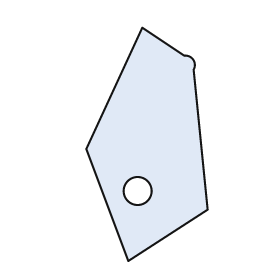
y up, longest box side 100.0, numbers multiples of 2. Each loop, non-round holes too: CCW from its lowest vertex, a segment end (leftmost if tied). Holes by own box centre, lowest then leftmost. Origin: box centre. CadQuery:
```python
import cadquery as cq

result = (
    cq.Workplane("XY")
    .moveTo(-8.0, -50.0)
    .lineTo(26.0, -28.0)
    .lineTo(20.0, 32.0)
    .threePointArc((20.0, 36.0), (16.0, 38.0))
    .lineTo(-2.0, 50.0)
    .lineTo(-26.0, -2.0)
    .close()
    .moveTo(-4.0, -20.0)
    .circle(6.0)
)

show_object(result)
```